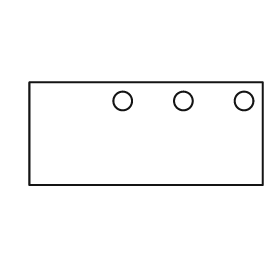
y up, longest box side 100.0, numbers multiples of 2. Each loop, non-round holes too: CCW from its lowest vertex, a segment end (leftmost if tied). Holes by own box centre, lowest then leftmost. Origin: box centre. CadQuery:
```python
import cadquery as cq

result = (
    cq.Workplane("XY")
    .moveTo(-50.0, -22.0)
    .lineTo(50.0, -22.0)
    .lineTo(50.0, 22.0)
    .lineTo(-50.0, 22.0)
    .close()
    .moveTo(-10.0, 14.0)
    .circle(4.0)
    .moveTo(16.0, 14.0)
    .circle(4.0)
    .moveTo(42.0, 14.0)
    .circle(4.0)
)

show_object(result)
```